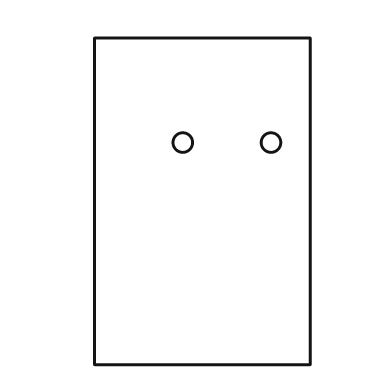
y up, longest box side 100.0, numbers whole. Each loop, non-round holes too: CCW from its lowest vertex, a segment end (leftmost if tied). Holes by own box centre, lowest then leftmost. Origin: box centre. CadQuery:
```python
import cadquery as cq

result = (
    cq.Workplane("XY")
    .moveTo(-33.0, -50.0)
    .lineTo(33.0, -50.0)
    .lineTo(33.0, 50.0)
    .lineTo(-33.0, 50.0)
    .close()
    .moveTo(-6.0, 18.0)
    .circle(3.0)
    .moveTo(21.0, 18.0)
    .circle(3.0)
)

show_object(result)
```